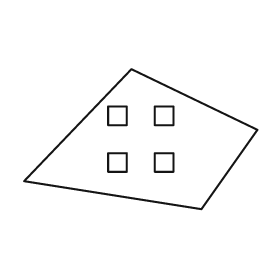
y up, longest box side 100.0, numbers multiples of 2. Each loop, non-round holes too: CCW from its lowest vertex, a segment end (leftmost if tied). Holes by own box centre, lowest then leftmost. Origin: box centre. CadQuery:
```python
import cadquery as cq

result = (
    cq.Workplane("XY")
    .moveTo(26.0, -30.0)
    .lineTo(50.0, 4.0)
    .lineTo(-4.0, 30.0)
    .lineTo(-50.0, -18.0)
    .close()
    .moveTo(-14.0, -14.0)
    .lineTo(-6.0, -14.0)
    .lineTo(-6.0, -6.0)
    .lineTo(-14.0, -6.0)
    .close()
    .moveTo(6.0, -14.0)
    .lineTo(14.0, -14.0)
    .lineTo(14.0, -6.0)
    .lineTo(6.0, -6.0)
    .close()
    .moveTo(-14.0, 6.0)
    .lineTo(-6.0, 6.0)
    .lineTo(-6.0, 14.0)
    .lineTo(-14.0, 14.0)
    .close()
    .moveTo(6.0, 6.0)
    .lineTo(14.0, 6.0)
    .lineTo(14.0, 14.0)
    .lineTo(6.0, 14.0)
    .close()
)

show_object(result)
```